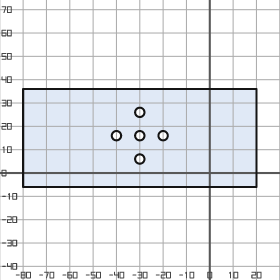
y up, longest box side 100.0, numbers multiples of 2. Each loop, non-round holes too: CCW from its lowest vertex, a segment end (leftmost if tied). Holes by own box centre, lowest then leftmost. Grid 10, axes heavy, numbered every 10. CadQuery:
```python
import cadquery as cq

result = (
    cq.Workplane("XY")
    .moveTo(-80.0, -6.0)
    .lineTo(20.0, -6.0)
    .lineTo(20.0, 36.0)
    .lineTo(-80.0, 36.0)
    .close()
    .moveTo(-30.0, 6.0)
    .circle(2.0)
    .moveTo(-40.0, 16.0)
    .circle(2.0)
    .moveTo(-30.0, 16.0)
    .circle(2.0)
    .moveTo(-20.0, 16.0)
    .circle(2.0)
    .moveTo(-30.0, 26.0)
    .circle(2.0)
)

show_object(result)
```